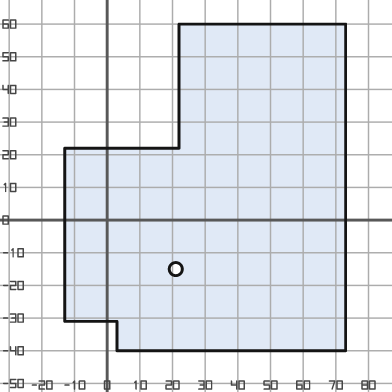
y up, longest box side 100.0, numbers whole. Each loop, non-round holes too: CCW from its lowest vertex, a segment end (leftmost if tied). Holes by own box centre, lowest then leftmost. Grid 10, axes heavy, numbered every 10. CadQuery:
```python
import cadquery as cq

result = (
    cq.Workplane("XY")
    .moveTo(3.0, -40.0)
    .lineTo(73.0, -40.0)
    .lineTo(73.0, 60.0)
    .lineTo(22.0, 60.0)
    .lineTo(22.0, 22.0)
    .lineTo(-13.0, 22.0)
    .lineTo(-13.0, -31.0)
    .lineTo(3.0, -31.0)
    .close()
    .moveTo(21.0, -15.0)
    .circle(2.0)
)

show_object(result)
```